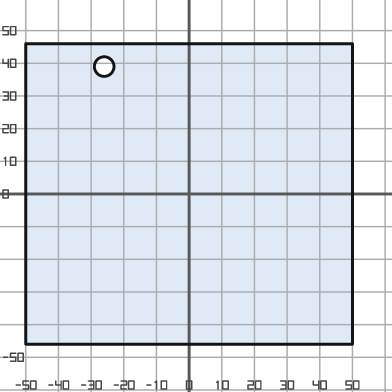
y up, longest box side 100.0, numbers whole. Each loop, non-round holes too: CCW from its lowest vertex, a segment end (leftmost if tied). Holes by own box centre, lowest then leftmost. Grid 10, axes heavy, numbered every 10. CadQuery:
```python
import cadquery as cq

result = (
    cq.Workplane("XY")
    .moveTo(-50.0, -46.0)
    .lineTo(50.0, -46.0)
    .lineTo(50.0, 46.0)
    .lineTo(-50.0, 46.0)
    .close()
    .moveTo(-26.0, 39.0)
    .circle(3.0)
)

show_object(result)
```